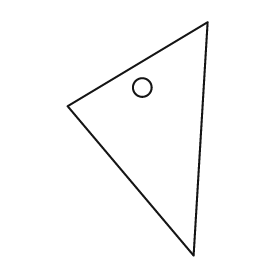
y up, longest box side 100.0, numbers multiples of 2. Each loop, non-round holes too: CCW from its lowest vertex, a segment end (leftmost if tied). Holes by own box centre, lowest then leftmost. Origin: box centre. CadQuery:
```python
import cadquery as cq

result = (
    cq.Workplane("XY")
    .moveTo(24.0, -50.0)
    .lineTo(30.0, 50.0)
    .lineTo(-30.0, 14.0)
    .close()
    .moveTo(2.0, 22.0)
    .circle(4.0)
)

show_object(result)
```